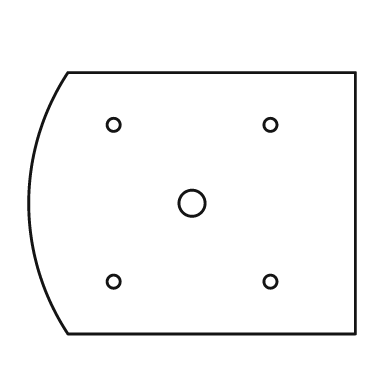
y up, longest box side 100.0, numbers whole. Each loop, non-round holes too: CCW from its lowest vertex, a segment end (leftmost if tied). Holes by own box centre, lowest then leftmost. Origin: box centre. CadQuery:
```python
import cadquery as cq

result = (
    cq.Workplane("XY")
    .moveTo(-38.0, -40.0)
    .lineTo(50.0, -40.0)
    .lineTo(50.0, 40.0)
    .lineTo(-38.0, 40.0)
    .threePointArc((-50.0, 0.0), (-38.0, -40.0))
    .close()
    .moveTo(-24.0, -24.0)
    .circle(2.0)
    .moveTo(24.0, -24.0)
    .circle(2.0)
    .moveTo(0.0, 0.0)
    .circle(4.0)
    .moveTo(-24.0, 24.0)
    .circle(2.0)
    .moveTo(24.0, 24.0)
    .circle(2.0)
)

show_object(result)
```